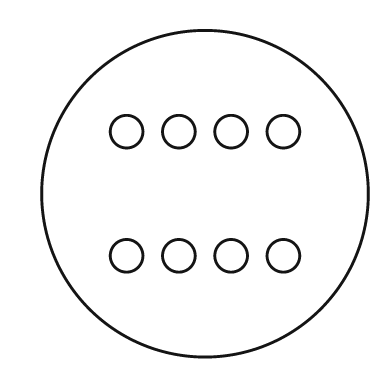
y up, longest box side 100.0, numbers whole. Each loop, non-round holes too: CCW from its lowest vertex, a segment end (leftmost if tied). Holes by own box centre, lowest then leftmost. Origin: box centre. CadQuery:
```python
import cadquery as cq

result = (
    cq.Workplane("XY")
    .moveTo(0.0, 0.0)
    .circle(50.0)
    .moveTo(-24.0, -19.0)
    .circle(5.0)
    .moveTo(-8.0, -19.0)
    .circle(5.0)
    .moveTo(8.0, -19.0)
    .circle(5.0)
    .moveTo(24.0, -19.0)
    .circle(5.0)
    .moveTo(-24.0, 19.0)
    .circle(5.0)
    .moveTo(-8.0, 19.0)
    .circle(5.0)
    .moveTo(8.0, 19.0)
    .circle(5.0)
    .moveTo(24.0, 19.0)
    .circle(5.0)
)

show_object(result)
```